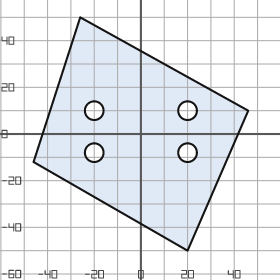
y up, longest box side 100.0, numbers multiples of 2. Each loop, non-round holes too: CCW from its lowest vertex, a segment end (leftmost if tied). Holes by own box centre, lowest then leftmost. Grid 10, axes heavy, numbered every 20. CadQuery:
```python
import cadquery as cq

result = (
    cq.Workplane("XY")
    .moveTo(20.0, -50.0)
    .lineTo(46.0, 10.0)
    .lineTo(-26.0, 50.0)
    .lineTo(-46.0, -12.0)
    .close()
    .moveTo(-20.0, -8.0)
    .circle(4.0)
    .moveTo(20.0, -8.0)
    .circle(4.0)
    .moveTo(-20.0, 10.0)
    .circle(4.0)
    .moveTo(20.0, 10.0)
    .circle(4.0)
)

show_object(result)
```